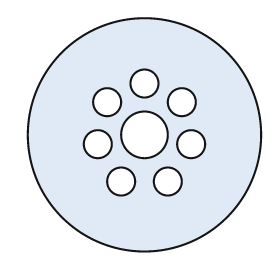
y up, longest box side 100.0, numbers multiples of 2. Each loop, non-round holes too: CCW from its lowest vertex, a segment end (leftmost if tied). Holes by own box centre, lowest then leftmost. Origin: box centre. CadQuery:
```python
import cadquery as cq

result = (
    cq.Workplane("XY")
    .moveTo(0.0, 0.0)
    .circle(50.0)
    .moveTo(-10.0, -20.0)
    .circle(6.0)
    .moveTo(10.0, -20.0)
    .circle(6.0)
    .moveTo(-20.0, -4.0)
    .circle(6.0)
    .moveTo(20.0, -4.0)
    .circle(6.0)
    .moveTo(0.0, 0.0)
    .circle(10.0)
    .moveTo(-16.0, 14.0)
    .circle(6.0)
    .moveTo(16.0, 14.0)
    .circle(6.0)
    .moveTo(0.0, 22.0)
    .circle(6.0)
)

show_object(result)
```